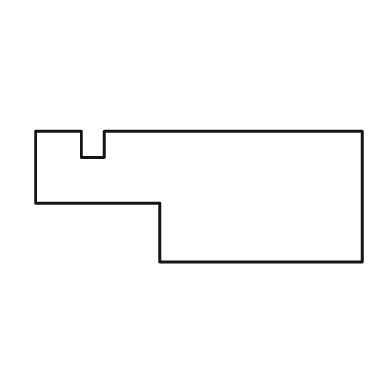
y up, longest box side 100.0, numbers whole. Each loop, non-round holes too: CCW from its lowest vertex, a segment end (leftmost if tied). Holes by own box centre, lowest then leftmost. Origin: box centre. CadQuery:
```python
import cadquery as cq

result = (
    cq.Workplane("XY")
    .moveTo(-12.0, -20.0)
    .lineTo(50.0, -20.0)
    .lineTo(50.0, 20.0)
    .lineTo(-29.0, 20.0)
    .lineTo(-29.0, 12.0)
    .lineTo(-36.0, 12.0)
    .lineTo(-36.0, 20.0)
    .lineTo(-50.0, 20.0)
    .lineTo(-50.0, -2.0)
    .lineTo(-12.0, -2.0)
    .close()
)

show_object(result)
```